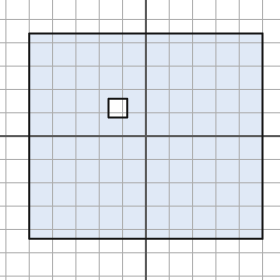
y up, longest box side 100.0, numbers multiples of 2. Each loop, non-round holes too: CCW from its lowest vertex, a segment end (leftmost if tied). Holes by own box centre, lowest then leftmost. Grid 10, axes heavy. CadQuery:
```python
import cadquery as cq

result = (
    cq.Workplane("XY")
    .moveTo(-50.0, -44.0)
    .lineTo(50.0, -44.0)
    .lineTo(50.0, 44.0)
    .lineTo(-50.0, 44.0)
    .close()
    .moveTo(-16.0, 8.0)
    .lineTo(-8.0, 8.0)
    .lineTo(-8.0, 16.0)
    .lineTo(-16.0, 16.0)
    .close()
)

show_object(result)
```